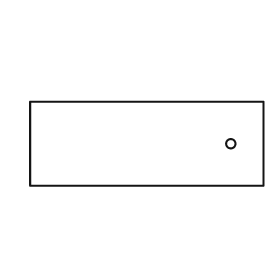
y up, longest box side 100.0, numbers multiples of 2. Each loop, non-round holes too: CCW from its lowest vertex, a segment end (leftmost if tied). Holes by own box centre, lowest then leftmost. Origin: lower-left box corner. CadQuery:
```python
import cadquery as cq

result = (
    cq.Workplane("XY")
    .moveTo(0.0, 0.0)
    .lineTo(100.0, 0.0)
    .lineTo(100.0, 36.0)
    .lineTo(0.0, 36.0)
    .close()
    .moveTo(86.0, 18.0)
    .circle(2.0)
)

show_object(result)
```